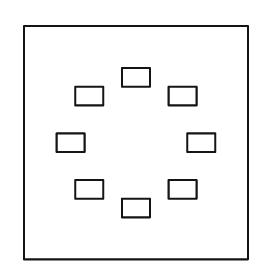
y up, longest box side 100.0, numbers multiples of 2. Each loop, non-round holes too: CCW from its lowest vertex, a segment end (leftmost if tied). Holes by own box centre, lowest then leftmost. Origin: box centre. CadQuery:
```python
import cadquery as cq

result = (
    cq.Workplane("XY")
    .moveTo(-48.0, -50.0)
    .lineTo(48.0, -50.0)
    .lineTo(48.0, 50.0)
    .lineTo(-48.0, 50.0)
    .close()
    .moveTo(-6.0, -32.0)
    .lineTo(6.0, -32.0)
    .lineTo(6.0, -24.0)
    .lineTo(-6.0, -24.0)
    .close()
    .moveTo(-26.0, -24.0)
    .lineTo(-14.0, -24.0)
    .lineTo(-14.0, -16.0)
    .lineTo(-26.0, -16.0)
    .close()
    .moveTo(14.0, -24.0)
    .lineTo(26.0, -24.0)
    .lineTo(26.0, -16.0)
    .lineTo(14.0, -16.0)
    .close()
    .moveTo(-34.0, -4.0)
    .lineTo(-22.0, -4.0)
    .lineTo(-22.0, 4.0)
    .lineTo(-34.0, 4.0)
    .close()
    .moveTo(22.0, -4.0)
    .lineTo(34.0, -4.0)
    .lineTo(34.0, 4.0)
    .lineTo(22.0, 4.0)
    .close()
    .moveTo(-26.0, 16.0)
    .lineTo(-14.0, 16.0)
    .lineTo(-14.0, 24.0)
    .lineTo(-26.0, 24.0)
    .close()
    .moveTo(14.0, 16.0)
    .lineTo(26.0, 16.0)
    .lineTo(26.0, 24.0)
    .lineTo(14.0, 24.0)
    .close()
    .moveTo(-6.0, 24.0)
    .lineTo(6.0, 24.0)
    .lineTo(6.0, 32.0)
    .lineTo(-6.0, 32.0)
    .close()
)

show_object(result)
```